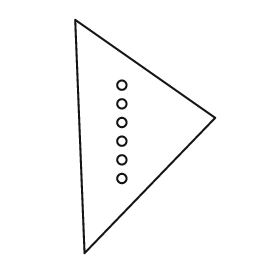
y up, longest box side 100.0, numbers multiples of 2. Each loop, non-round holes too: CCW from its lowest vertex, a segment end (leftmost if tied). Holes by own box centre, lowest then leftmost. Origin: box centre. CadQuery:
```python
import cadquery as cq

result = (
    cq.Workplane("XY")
    .moveTo(-26.0, -50.0)
    .lineTo(30.0, 8.0)
    .lineTo(-30.0, 50.0)
    .close()
    .moveTo(-10.0, -18.0)
    .circle(2.0)
    .moveTo(-10.0, -10.0)
    .circle(2.0)
    .moveTo(-10.0, -2.0)
    .circle(2.0)
    .moveTo(-10.0, 6.0)
    .circle(2.0)
    .moveTo(-10.0, 14.0)
    .circle(2.0)
    .moveTo(-10.0, 22.0)
    .circle(2.0)
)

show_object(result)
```